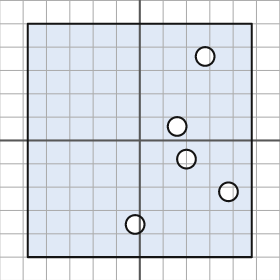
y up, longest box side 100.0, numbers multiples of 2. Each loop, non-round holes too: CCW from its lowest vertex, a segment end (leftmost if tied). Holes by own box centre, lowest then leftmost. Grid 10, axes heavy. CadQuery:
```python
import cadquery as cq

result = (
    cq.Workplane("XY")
    .moveTo(-48.0, -50.0)
    .lineTo(48.0, -50.0)
    .lineTo(48.0, 50.0)
    .lineTo(-48.0, 50.0)
    .close()
    .moveTo(-2.0, -36.0)
    .circle(4.0)
    .moveTo(38.0, -22.0)
    .circle(4.0)
    .moveTo(20.0, -8.0)
    .circle(4.0)
    .moveTo(16.0, 6.0)
    .circle(4.0)
    .moveTo(28.0, 36.0)
    .circle(4.0)
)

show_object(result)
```